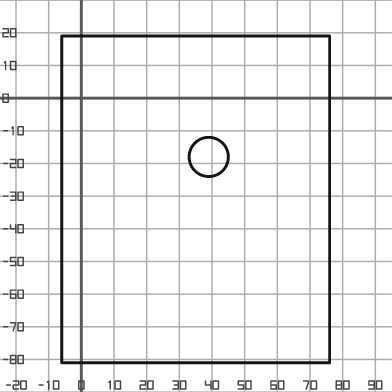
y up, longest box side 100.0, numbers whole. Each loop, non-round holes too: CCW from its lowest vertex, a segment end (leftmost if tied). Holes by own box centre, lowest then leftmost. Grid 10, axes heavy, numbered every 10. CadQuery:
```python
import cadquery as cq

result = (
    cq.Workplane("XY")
    .moveTo(-6.0, -81.0)
    .lineTo(76.0, -81.0)
    .lineTo(76.0, 19.0)
    .lineTo(-6.0, 19.0)
    .close()
    .moveTo(39.0, -18.0)
    .circle(6.0)
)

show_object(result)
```